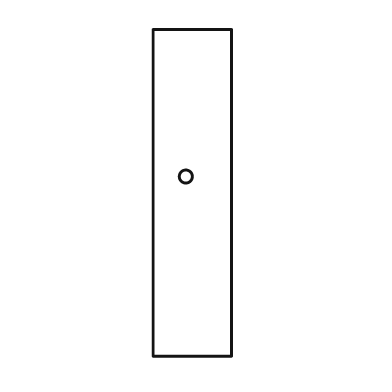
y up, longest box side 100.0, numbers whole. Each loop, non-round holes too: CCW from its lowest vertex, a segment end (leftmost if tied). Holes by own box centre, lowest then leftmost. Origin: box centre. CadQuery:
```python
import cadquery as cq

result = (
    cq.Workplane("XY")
    .moveTo(-12.0, -50.0)
    .lineTo(12.0, -50.0)
    .lineTo(12.0, 50.0)
    .lineTo(-12.0, 50.0)
    .close()
    .moveTo(-2.0, 5.0)
    .circle(2.0)
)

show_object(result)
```